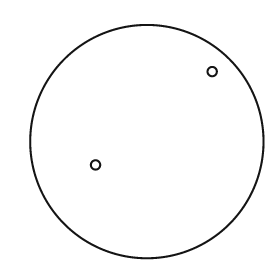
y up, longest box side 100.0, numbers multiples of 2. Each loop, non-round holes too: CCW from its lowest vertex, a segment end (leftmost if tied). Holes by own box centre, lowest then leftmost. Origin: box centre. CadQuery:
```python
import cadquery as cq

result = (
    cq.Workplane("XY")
    .moveTo(0.0, 0.0)
    .circle(50.0)
    .moveTo(-22.0, -10.0)
    .circle(2.0)
    .moveTo(28.0, 30.0)
    .circle(2.0)
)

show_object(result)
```